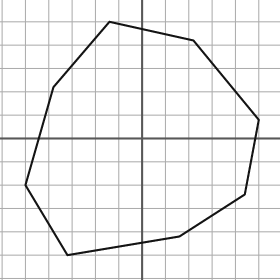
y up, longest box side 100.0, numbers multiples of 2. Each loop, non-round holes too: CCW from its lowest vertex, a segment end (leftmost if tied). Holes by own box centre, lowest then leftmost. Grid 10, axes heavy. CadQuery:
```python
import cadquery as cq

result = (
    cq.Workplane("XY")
    .moveTo(-32.0, -50.0)
    .lineTo(16.0, -42.0)
    .lineTo(44.0, -24.0)
    .lineTo(50.0, 8.0)
    .lineTo(22.0, 42.0)
    .lineTo(-14.0, 50.0)
    .lineTo(-38.0, 22.0)
    .lineTo(-50.0, -20.0)
    .close()
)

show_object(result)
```